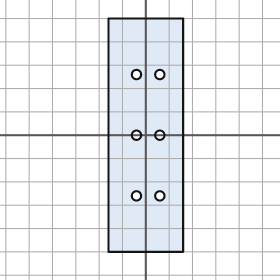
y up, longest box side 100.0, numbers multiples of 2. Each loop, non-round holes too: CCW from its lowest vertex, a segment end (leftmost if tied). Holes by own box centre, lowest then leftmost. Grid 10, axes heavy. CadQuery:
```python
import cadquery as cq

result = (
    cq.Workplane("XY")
    .moveTo(-16.0, -50.0)
    .lineTo(16.0, -50.0)
    .lineTo(16.0, 50.0)
    .lineTo(-16.0, 50.0)
    .close()
    .moveTo(-4.0, -26.0)
    .circle(2.0)
    .moveTo(6.0, -26.0)
    .circle(2.0)
    .moveTo(-4.0, 0.0)
    .circle(2.0)
    .moveTo(6.0, 0.0)
    .circle(2.0)
    .moveTo(-4.0, 26.0)
    .circle(2.0)
    .moveTo(6.0, 26.0)
    .circle(2.0)
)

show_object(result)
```